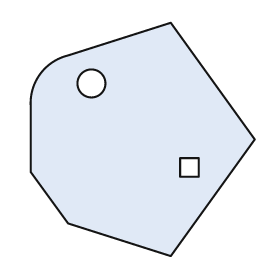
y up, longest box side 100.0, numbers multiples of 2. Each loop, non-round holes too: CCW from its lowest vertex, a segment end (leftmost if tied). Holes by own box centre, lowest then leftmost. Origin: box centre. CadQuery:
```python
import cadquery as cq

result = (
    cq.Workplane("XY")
    .moveTo(12.0, -50.0)
    .lineTo(48.0, 0.0)
    .lineTo(12.0, 50.0)
    .lineTo(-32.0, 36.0)
    .threePointArc((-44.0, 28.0), (-48.0, 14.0))
    .lineTo(-48.0, -14.0)
    .lineTo(-32.0, -36.0)
    .close()
    .moveTo(16.0, -16.0)
    .lineTo(24.0, -16.0)
    .lineTo(24.0, -8.0)
    .lineTo(16.0, -8.0)
    .close()
    .moveTo(-22.0, 24.0)
    .circle(6.0)
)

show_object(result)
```